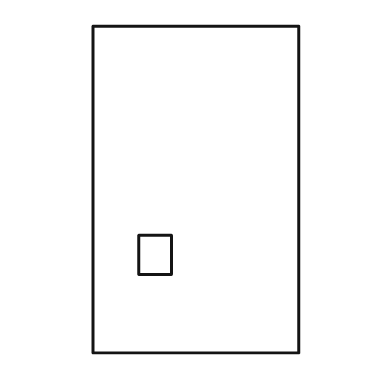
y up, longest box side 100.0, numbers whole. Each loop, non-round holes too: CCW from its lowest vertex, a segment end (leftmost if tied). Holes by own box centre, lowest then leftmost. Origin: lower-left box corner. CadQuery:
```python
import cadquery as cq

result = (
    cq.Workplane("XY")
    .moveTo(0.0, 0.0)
    .lineTo(63.0, 0.0)
    .lineTo(63.0, 100.0)
    .lineTo(0.0, 100.0)
    .close()
    .moveTo(14.0, 24.0)
    .lineTo(24.0, 24.0)
    .lineTo(24.0, 36.0)
    .lineTo(14.0, 36.0)
    .close()
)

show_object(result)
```